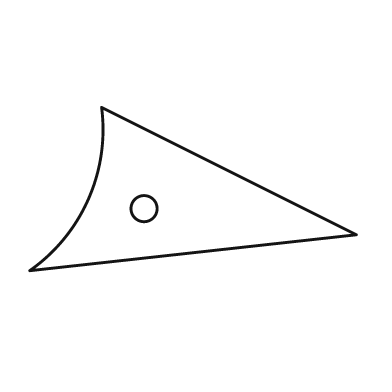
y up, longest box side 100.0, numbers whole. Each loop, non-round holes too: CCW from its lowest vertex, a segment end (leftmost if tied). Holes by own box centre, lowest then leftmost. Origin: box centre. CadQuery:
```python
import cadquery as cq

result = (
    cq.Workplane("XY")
    .moveTo(-50.0, -25.0)
    .lineTo(50.0, -14.0)
    .lineTo(-28.0, 25.0)
    .threePointArc((-32.0, -3.0), (-50.0, -25.0))
    .close()
    .moveTo(-15.0, -6.0)
    .circle(4.0)
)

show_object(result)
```